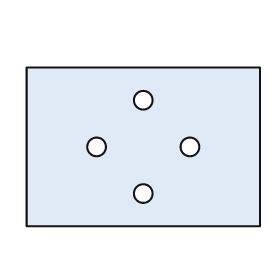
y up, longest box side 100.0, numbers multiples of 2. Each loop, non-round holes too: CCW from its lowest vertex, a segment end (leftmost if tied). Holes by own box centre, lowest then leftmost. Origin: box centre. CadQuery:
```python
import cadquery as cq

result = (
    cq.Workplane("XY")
    .moveTo(-50.0, -34.0)
    .lineTo(50.0, -34.0)
    .lineTo(50.0, 34.0)
    .lineTo(-50.0, 34.0)
    .close()
    .moveTo(0.0, -20.0)
    .circle(4.0)
    .moveTo(-20.0, 0.0)
    .circle(4.0)
    .moveTo(20.0, 0.0)
    .circle(4.0)
    .moveTo(0.0, 20.0)
    .circle(4.0)
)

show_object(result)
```